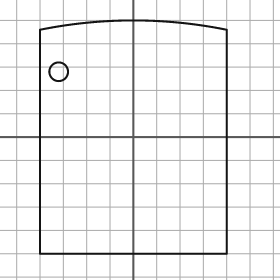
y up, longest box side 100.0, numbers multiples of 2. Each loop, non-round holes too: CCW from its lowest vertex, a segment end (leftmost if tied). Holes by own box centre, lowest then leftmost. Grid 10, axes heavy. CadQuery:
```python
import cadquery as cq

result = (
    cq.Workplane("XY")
    .moveTo(-40.0, -50.0)
    .lineTo(40.0, -50.0)
    .lineTo(40.0, 46.0)
    .threePointArc((0.0, 50.0), (-40.0, 46.0))
    .close()
    .moveTo(-32.0, 28.0)
    .circle(4.0)
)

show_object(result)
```